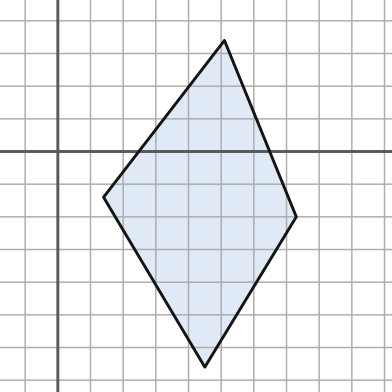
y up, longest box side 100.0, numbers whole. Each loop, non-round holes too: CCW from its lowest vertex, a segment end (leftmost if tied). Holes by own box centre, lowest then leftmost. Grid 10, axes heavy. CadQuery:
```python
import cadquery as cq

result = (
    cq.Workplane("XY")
    .moveTo(45.0, -66.0)
    .lineTo(73.0, -20.0)
    .lineTo(51.0, 34.0)
    .lineTo(14.0, -14.0)
    .close()
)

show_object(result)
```